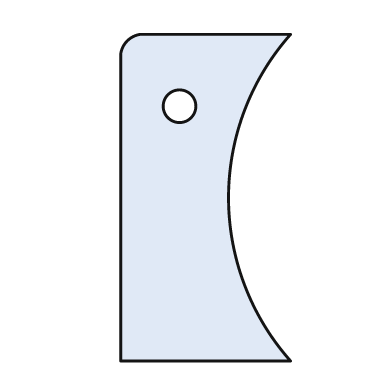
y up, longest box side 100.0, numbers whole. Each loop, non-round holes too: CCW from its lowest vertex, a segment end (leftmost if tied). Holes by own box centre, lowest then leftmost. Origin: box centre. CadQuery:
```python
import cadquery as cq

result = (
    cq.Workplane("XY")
    .moveTo(-26.0, -50.0)
    .lineTo(26.0, -50.0)
    .threePointArc((7.0, 0.0), (26.0, 50.0))
    .lineTo(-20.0, 50.0)
    .threePointArc((-24.0, 48.0), (-26.0, 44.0))
    .close()
    .moveTo(-8.0, 28.0)
    .circle(5.0)
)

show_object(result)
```